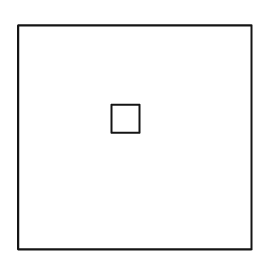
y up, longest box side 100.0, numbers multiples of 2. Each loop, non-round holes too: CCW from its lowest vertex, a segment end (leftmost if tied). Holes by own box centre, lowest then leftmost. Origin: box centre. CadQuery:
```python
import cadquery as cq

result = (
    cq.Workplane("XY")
    .moveTo(-50.0, -48.0)
    .lineTo(50.0, -48.0)
    .lineTo(50.0, 48.0)
    .lineTo(-50.0, 48.0)
    .close()
    .moveTo(-10.0, 2.0)
    .lineTo(2.0, 2.0)
    .lineTo(2.0, 14.0)
    .lineTo(-10.0, 14.0)
    .close()
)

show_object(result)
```